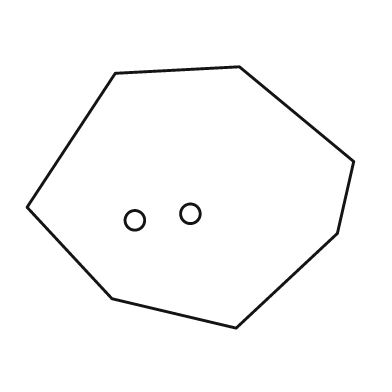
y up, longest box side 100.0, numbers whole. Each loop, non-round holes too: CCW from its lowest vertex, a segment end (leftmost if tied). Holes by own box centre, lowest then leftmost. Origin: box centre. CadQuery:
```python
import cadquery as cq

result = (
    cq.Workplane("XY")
    .moveTo(14.0, -40.0)
    .lineTo(45.0, -11.0)
    .lineTo(50.0, 11.0)
    .lineTo(15.0, 40.0)
    .lineTo(-23.0, 38.0)
    .lineTo(-50.0, -3.0)
    .lineTo(-24.0, -31.0)
    .close()
    .moveTo(-17.0, -7.0)
    .circle(3.0)
    .moveTo(0.0, -5.0)
    .circle(3.0)
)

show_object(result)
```